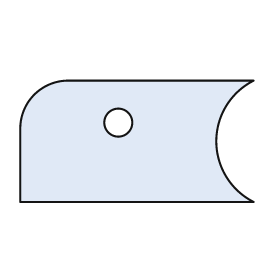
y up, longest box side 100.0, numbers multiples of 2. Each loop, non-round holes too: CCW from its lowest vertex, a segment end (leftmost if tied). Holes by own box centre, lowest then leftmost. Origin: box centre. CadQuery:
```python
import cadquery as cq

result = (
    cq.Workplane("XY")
    .moveTo(-50.0, -26.0)
    .lineTo(50.0, -26.0)
    .threePointArc((34.0, 0.0), (50.0, 26.0))
    .lineTo(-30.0, 26.0)
    .threePointArc((-44.0, 20.0), (-50.0, 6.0))
    .close()
    .moveTo(-8.0, 8.0)
    .circle(6.0)
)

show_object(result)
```